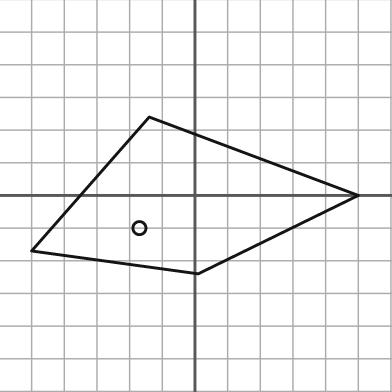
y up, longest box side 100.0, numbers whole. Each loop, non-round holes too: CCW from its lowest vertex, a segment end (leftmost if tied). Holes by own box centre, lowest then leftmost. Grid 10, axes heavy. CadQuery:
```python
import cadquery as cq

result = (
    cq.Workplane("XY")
    .moveTo(1.0, -24.0)
    .lineTo(50.0, 0.0)
    .lineTo(-14.0, 24.0)
    .lineTo(-50.0, -17.0)
    .close()
    .moveTo(-17.0, -10.0)
    .circle(2.0)
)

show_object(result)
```